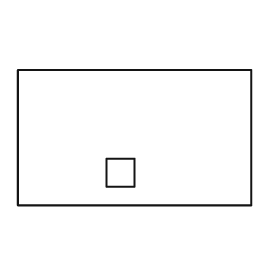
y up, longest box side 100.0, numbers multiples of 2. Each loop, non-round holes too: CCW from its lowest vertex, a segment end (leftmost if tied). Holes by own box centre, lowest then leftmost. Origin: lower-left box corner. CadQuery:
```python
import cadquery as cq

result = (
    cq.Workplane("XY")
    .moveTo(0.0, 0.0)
    .lineTo(100.0, 0.0)
    .lineTo(100.0, 58.0)
    .lineTo(0.0, 58.0)
    .close()
    .moveTo(38.0, 8.0)
    .lineTo(50.0, 8.0)
    .lineTo(50.0, 20.0)
    .lineTo(38.0, 20.0)
    .close()
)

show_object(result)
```